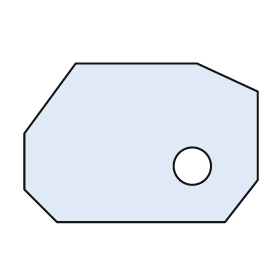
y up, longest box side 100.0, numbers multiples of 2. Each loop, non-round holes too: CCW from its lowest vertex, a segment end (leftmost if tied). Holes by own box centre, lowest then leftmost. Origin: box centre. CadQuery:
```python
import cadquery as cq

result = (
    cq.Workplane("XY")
    .moveTo(-36.0, -34.0)
    .lineTo(36.0, -34.0)
    .lineTo(50.0, -16.0)
    .lineTo(50.0, 22.0)
    .lineTo(24.0, 34.0)
    .lineTo(-28.0, 34.0)
    .lineTo(-50.0, 4.0)
    .lineTo(-50.0, -20.0)
    .close()
    .moveTo(22.0, -10.0)
    .circle(8.0)
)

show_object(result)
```